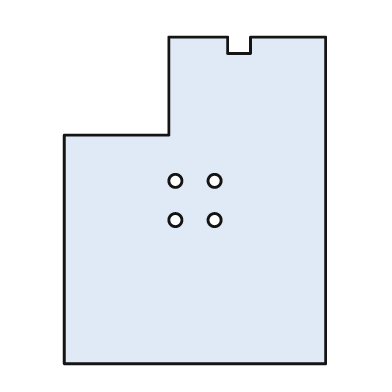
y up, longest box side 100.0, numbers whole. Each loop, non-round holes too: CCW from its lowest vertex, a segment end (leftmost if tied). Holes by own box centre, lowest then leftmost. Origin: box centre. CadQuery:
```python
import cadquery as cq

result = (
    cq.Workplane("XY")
    .moveTo(-40.0, -50.0)
    .lineTo(40.0, -50.0)
    .lineTo(40.0, 50.0)
    .lineTo(17.0, 50.0)
    .lineTo(17.0, 45.0)
    .lineTo(10.0, 45.0)
    .lineTo(10.0, 50.0)
    .lineTo(-8.0, 50.0)
    .lineTo(-8.0, 20.0)
    .lineTo(-40.0, 20.0)
    .close()
    .moveTo(-6.0, -6.0)
    .circle(2.0)
    .moveTo(6.0, -6.0)
    .circle(2.0)
    .moveTo(-6.0, 6.0)
    .circle(2.0)
    .moveTo(6.0, 6.0)
    .circle(2.0)
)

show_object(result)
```